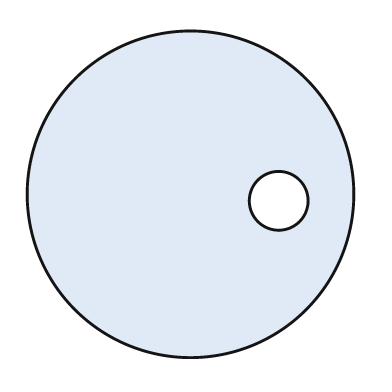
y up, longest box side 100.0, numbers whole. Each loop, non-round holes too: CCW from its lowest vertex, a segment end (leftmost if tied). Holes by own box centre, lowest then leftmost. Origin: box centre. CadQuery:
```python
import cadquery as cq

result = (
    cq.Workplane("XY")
    .moveTo(0.0, 0.0)
    .circle(50.0)
    .moveTo(27.0, -2.0)
    .circle(9.0)
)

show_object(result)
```